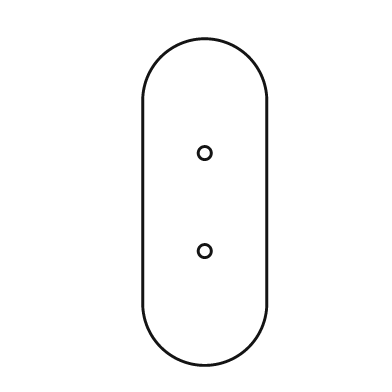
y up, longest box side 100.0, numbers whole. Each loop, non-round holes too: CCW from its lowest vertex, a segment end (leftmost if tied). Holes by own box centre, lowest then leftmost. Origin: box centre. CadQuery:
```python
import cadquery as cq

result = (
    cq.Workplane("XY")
    .moveTo(-19.0, -31.0)
    .threePointArc((0.0, -50.0), (19.0, -31.0))
    .lineTo(19.0, 31.0)
    .threePointArc((0.0, 50.0), (-19.0, 31.0))
    .close()
    .moveTo(0.0, -15.0)
    .circle(2.0)
    .moveTo(0.0, 15.0)
    .circle(2.0)
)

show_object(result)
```